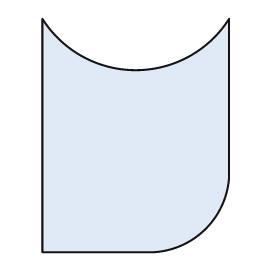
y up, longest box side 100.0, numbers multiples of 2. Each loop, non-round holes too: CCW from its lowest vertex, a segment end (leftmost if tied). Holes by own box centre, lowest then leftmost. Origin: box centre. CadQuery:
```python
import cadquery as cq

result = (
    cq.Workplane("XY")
    .moveTo(-40.0, -50.0)
    .lineTo(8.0, -50.0)
    .threePointArc((30.0, -40.0), (40.0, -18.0))
    .lineTo(40.0, 50.0)
    .threePointArc((0.0, 28.0), (-40.0, 50.0))
    .close()
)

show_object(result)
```